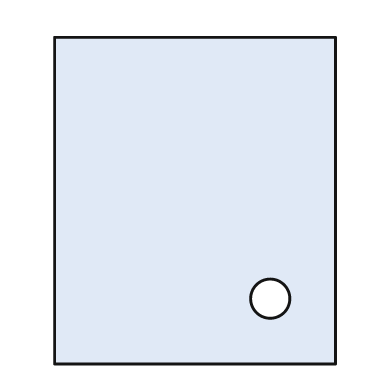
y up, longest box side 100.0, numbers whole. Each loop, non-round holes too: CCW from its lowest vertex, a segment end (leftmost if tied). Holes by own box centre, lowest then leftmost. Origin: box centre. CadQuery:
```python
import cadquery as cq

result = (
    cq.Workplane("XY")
    .moveTo(-43.0, -50.0)
    .lineTo(43.0, -50.0)
    .lineTo(43.0, 50.0)
    .lineTo(-43.0, 50.0)
    .close()
    .moveTo(23.0, -30.0)
    .circle(6.0)
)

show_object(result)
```